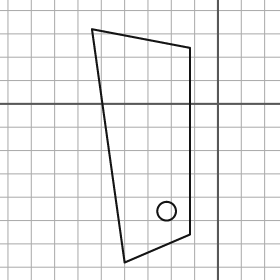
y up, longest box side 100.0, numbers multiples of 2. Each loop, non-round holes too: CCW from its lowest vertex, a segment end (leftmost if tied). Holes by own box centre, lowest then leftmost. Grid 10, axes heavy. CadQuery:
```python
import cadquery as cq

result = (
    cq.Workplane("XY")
    .moveTo(-40.0, -68.0)
    .lineTo(-12.0, -56.0)
    .lineTo(-12.0, 24.0)
    .lineTo(-54.0, 32.0)
    .close()
    .moveTo(-22.0, -46.0)
    .circle(4.0)
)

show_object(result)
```